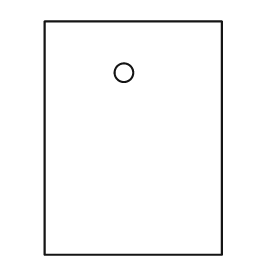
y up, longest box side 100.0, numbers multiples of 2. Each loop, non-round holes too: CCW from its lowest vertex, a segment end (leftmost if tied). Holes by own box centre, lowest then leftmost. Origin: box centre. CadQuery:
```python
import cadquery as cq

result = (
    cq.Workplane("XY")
    .moveTo(-38.0, -50.0)
    .lineTo(38.0, -50.0)
    .lineTo(38.0, 50.0)
    .lineTo(-38.0, 50.0)
    .close()
    .moveTo(-4.0, 28.0)
    .circle(4.0)
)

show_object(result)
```